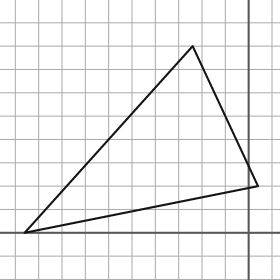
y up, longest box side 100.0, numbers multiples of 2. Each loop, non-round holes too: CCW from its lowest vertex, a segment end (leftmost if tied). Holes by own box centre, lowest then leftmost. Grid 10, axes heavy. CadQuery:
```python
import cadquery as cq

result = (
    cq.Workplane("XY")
    .moveTo(-96.0, 0.0)
    .lineTo(4.0, 20.0)
    .lineTo(-24.0, 80.0)
    .close()
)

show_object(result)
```